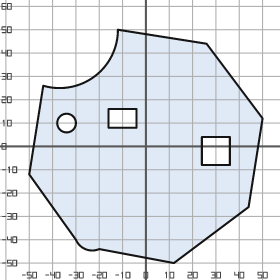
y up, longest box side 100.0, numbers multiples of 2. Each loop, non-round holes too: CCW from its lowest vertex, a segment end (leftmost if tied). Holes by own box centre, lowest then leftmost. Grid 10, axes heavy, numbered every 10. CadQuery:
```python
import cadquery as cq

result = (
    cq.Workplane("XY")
    .moveTo(12.0, -50.0)
    .lineTo(44.0, -26.0)
    .lineTo(50.0, 12.0)
    .lineTo(26.0, 44.0)
    .lineTo(-12.0, 50.0)
    .threePointArc((-22.0, 30.0), (-44.0, 26.0))
    .lineTo(-50.0, -12.0)
    .lineTo(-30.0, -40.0)
    .threePointArc((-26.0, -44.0), (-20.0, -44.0))
    .close()
    .moveTo(24.0, -8.0)
    .lineTo(36.0, -8.0)
    .lineTo(36.0, 4.0)
    .lineTo(24.0, 4.0)
    .close()
    .moveTo(-34.0, 10.0)
    .circle(4.0)
    .moveTo(-16.0, 8.0)
    .lineTo(-4.0, 8.0)
    .lineTo(-4.0, 16.0)
    .lineTo(-16.0, 16.0)
    .close()
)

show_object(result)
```